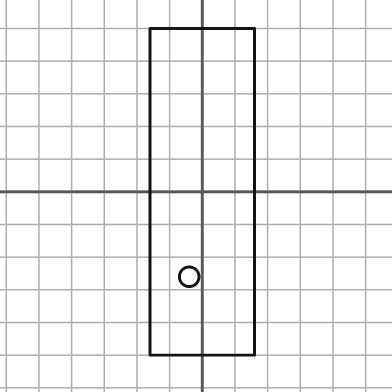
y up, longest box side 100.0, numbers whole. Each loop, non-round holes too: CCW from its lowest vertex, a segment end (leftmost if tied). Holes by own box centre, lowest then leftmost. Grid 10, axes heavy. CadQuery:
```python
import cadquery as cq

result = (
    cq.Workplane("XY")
    .moveTo(-16.0, -50.0)
    .lineTo(16.0, -50.0)
    .lineTo(16.0, 50.0)
    .lineTo(-16.0, 50.0)
    .close()
    .moveTo(-4.0, -26.0)
    .circle(3.0)
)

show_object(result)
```